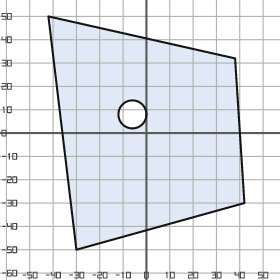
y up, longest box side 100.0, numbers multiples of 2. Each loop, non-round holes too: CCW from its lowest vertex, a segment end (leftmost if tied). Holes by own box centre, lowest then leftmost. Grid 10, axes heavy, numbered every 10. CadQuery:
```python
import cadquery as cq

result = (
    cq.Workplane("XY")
    .moveTo(-30.0, -50.0)
    .lineTo(42.0, -30.0)
    .lineTo(38.0, 32.0)
    .lineTo(-42.0, 50.0)
    .close()
    .moveTo(-6.0, 8.0)
    .circle(6.0)
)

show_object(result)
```